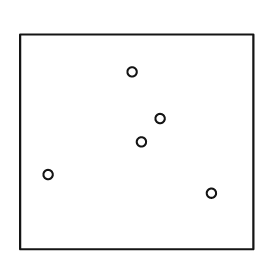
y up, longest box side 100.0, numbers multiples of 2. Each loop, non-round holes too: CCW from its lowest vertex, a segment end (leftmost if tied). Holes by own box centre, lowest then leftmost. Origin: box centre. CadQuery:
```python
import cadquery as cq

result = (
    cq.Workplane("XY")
    .moveTo(-50.0, -46.0)
    .lineTo(50.0, -46.0)
    .lineTo(50.0, 46.0)
    .lineTo(-50.0, 46.0)
    .close()
    .moveTo(32.0, -22.0)
    .circle(2.0)
    .moveTo(-38.0, -14.0)
    .circle(2.0)
    .moveTo(2.0, 0.0)
    .circle(2.0)
    .moveTo(10.0, 10.0)
    .circle(2.0)
    .moveTo(-2.0, 30.0)
    .circle(2.0)
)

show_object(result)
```